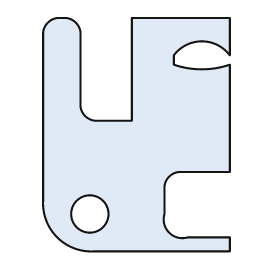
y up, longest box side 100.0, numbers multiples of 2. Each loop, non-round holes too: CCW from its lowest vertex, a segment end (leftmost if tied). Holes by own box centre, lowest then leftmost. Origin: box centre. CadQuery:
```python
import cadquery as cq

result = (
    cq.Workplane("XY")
    .moveTo(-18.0, -50.0)
    .lineTo(40.0, -50.0)
    .lineTo(40.0, -44.0)
    .lineTo(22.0, -44.0)
    .threePointArc((14.0, -42.0), (12.0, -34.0))
    .lineTo(12.0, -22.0)
    .threePointArc((14.0, -18.0), (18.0, -16.0))
    .lineTo(40.0, -16.0)
    .lineTo(40.0, 30.0)
    .threePointArc((28.0, 28.0), (16.0, 30.0))
    .lineTo(16.0, 34.0)
    .threePointArc((28.0, 40.0), (40.0, 34.0))
    .lineTo(40.0, 50.0)
    .lineTo(-2.0, 50.0)
    .lineTo(-2.0, 6.0)
    .lineTo(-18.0, 6.0)
    .threePointArc((-22.0, 8.0), (-24.0, 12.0))
    .lineTo(-24.0, 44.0)
    .threePointArc((-26.0, 48.0), (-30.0, 50.0))
    .lineTo(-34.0, 50.0)
    .threePointArc((-38.0, 48.0), (-40.0, 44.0))
    .lineTo(-40.0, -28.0)
    .threePointArc((-34.0, -44.0), (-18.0, -50.0))
    .close()
    .moveTo(-20.0, -34.0)
    .circle(8.0)
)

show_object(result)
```